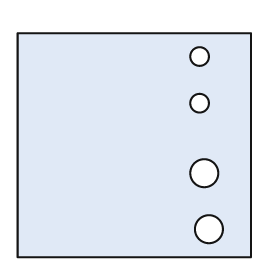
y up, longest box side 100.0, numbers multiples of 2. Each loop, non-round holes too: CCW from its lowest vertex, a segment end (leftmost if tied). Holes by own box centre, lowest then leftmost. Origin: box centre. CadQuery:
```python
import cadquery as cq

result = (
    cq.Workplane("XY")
    .moveTo(-50.0, -48.0)
    .lineTo(50.0, -48.0)
    .lineTo(50.0, 48.0)
    .lineTo(-50.0, 48.0)
    .close()
    .moveTo(32.0, -36.0)
    .circle(6.0)
    .moveTo(30.0, -12.0)
    .circle(6.0)
    .moveTo(28.0, 18.0)
    .circle(4.0)
    .moveTo(28.0, 38.0)
    .circle(4.0)
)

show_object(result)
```